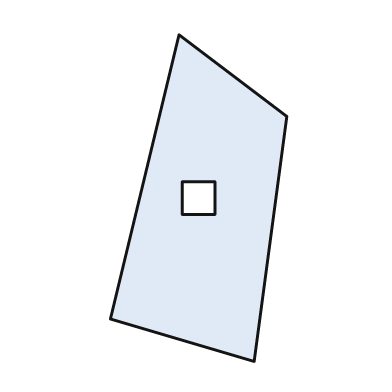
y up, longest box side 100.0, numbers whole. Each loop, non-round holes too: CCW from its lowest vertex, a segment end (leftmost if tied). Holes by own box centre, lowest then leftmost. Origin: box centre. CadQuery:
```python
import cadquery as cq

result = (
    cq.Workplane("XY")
    .moveTo(17.0, -50.0)
    .lineTo(27.0, 25.0)
    .lineTo(-6.0, 50.0)
    .lineTo(-27.0, -37.0)
    .close()
    .moveTo(-5.0, -5.0)
    .lineTo(5.0, -5.0)
    .lineTo(5.0, 5.0)
    .lineTo(-5.0, 5.0)
    .close()
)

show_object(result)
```